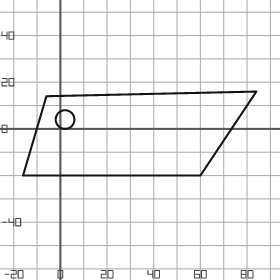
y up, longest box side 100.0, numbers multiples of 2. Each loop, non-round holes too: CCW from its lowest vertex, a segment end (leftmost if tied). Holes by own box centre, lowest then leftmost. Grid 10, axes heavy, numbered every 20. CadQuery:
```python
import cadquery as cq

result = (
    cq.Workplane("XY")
    .moveTo(-16.0, -20.0)
    .lineTo(60.0, -20.0)
    .lineTo(84.0, 16.0)
    .lineTo(-6.0, 14.0)
    .close()
    .moveTo(2.0, 4.0)
    .circle(4.0)
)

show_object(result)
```